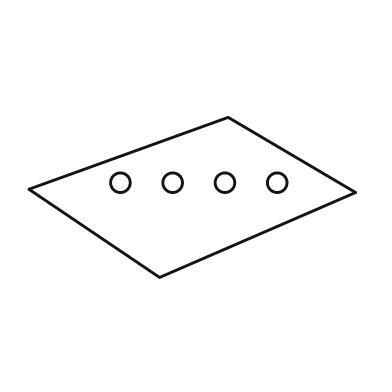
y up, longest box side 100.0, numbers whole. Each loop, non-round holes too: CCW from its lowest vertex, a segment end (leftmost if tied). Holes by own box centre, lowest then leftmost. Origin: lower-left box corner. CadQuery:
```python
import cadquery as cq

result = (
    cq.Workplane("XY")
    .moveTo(40.0, 0.0)
    .lineTo(100.0, 26.0)
    .lineTo(61.0, 49.0)
    .lineTo(0.0, 27.0)
    .close()
    .moveTo(28.0, 29.0)
    .circle(3.0)
    .moveTo(44.0, 29.0)
    .circle(3.0)
    .moveTo(60.0, 29.0)
    .circle(3.0)
    .moveTo(76.0, 29.0)
    .circle(3.0)
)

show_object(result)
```